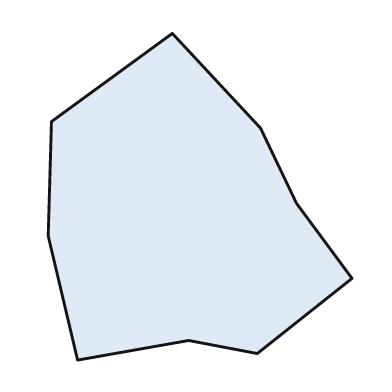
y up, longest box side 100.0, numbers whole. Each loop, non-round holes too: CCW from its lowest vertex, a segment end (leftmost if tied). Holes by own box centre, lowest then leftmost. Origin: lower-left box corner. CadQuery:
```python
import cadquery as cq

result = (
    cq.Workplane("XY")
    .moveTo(9.0, 0.0)
    .lineTo(43.0, 6.0)
    .lineTo(64.0, 2.0)
    .lineTo(93.0, 25.0)
    .lineTo(76.0, 48.0)
    .lineTo(65.0, 71.0)
    .lineTo(38.0, 100.0)
    .lineTo(1.0, 73.0)
    .lineTo(0.0, 38.0)
    .close()
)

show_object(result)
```